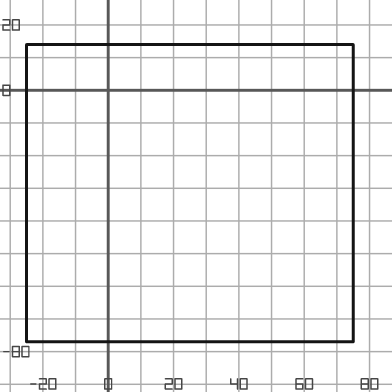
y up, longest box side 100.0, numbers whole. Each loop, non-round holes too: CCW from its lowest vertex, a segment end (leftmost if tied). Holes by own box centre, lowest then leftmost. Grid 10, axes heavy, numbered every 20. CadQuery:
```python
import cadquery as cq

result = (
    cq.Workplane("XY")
    .moveTo(-25.0, -77.0)
    .lineTo(75.0, -77.0)
    .lineTo(75.0, 14.0)
    .lineTo(-25.0, 14.0)
    .close()
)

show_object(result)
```